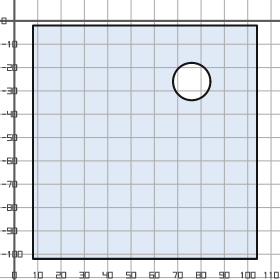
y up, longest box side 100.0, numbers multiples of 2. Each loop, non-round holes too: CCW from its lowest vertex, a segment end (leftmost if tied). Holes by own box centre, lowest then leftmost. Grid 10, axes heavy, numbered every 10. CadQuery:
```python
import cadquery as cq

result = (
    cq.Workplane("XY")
    .moveTo(8.0, -102.0)
    .lineTo(104.0, -102.0)
    .lineTo(104.0, -2.0)
    .lineTo(8.0, -2.0)
    .close()
    .moveTo(76.0, -26.0)
    .circle(8.0)
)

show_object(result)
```